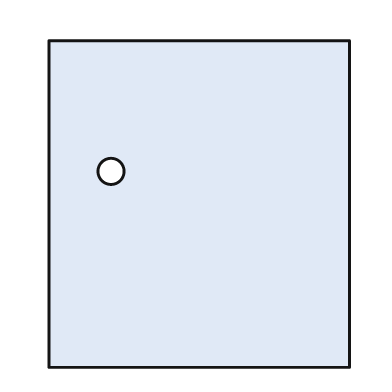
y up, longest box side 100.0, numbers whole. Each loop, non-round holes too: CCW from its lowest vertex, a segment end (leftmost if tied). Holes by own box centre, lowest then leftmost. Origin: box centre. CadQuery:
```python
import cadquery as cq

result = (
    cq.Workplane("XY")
    .moveTo(-46.0, -50.0)
    .lineTo(46.0, -50.0)
    .lineTo(46.0, 50.0)
    .lineTo(-46.0, 50.0)
    .close()
    .moveTo(-27.0, 10.0)
    .circle(4.0)
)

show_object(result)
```